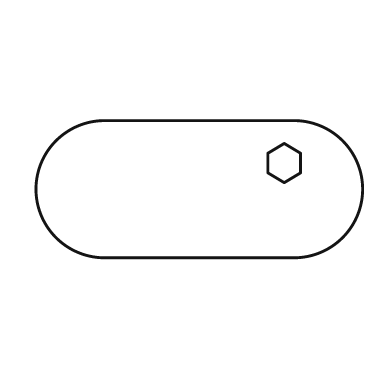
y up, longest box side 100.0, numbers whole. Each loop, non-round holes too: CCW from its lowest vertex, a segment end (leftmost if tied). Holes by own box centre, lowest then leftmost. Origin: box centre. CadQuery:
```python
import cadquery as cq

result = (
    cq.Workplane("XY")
    .moveTo(-29.0, -21.0)
    .lineTo(29.0, -21.0)
    .threePointArc((50.0, 0.0), (29.0, 21.0))
    .lineTo(-29.0, 21.0)
    .threePointArc((-50.0, 0.0), (-29.0, -21.0))
    .close()
    .moveTo(26.0, 2.0)
    .lineTo(31.0, 5.0)
    .lineTo(31.0, 11.0)
    .lineTo(26.0, 14.0)
    .lineTo(21.0, 11.0)
    .lineTo(21.0, 5.0)
    .close()
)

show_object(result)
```